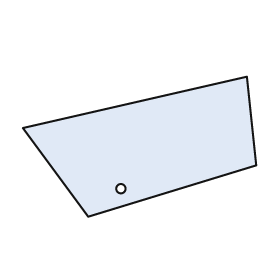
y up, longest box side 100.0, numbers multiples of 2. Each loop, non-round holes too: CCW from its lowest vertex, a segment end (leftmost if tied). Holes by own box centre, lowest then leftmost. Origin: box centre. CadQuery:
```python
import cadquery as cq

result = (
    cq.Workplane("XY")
    .moveTo(-22.0, -30.0)
    .lineTo(50.0, -8.0)
    .lineTo(46.0, 30.0)
    .lineTo(-50.0, 8.0)
    .close()
    .moveTo(-8.0, -18.0)
    .circle(2.0)
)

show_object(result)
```